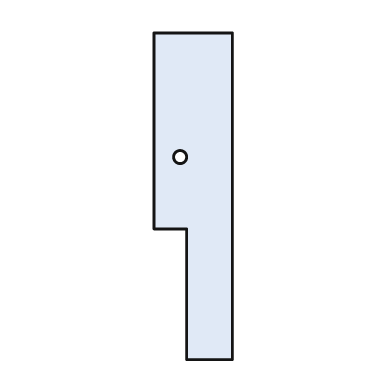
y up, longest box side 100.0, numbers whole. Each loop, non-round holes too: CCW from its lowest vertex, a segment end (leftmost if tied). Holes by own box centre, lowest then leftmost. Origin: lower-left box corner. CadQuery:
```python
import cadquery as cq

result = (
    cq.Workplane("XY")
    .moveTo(10.0, 0.0)
    .lineTo(24.0, 0.0)
    .lineTo(24.0, 100.0)
    .lineTo(0.0, 100.0)
    .lineTo(0.0, 40.0)
    .lineTo(10.0, 40.0)
    .close()
    .moveTo(8.0, 62.0)
    .circle(2.0)
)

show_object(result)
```